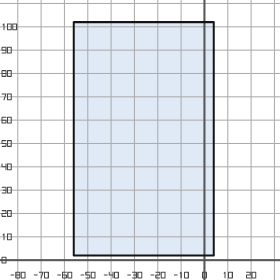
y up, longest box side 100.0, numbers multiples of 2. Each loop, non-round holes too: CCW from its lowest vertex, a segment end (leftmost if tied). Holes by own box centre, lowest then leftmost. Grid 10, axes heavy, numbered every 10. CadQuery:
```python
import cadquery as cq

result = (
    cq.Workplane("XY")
    .moveTo(-56.0, 2.0)
    .lineTo(4.0, 2.0)
    .lineTo(4.0, 102.0)
    .lineTo(-56.0, 102.0)
    .close()
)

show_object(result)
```